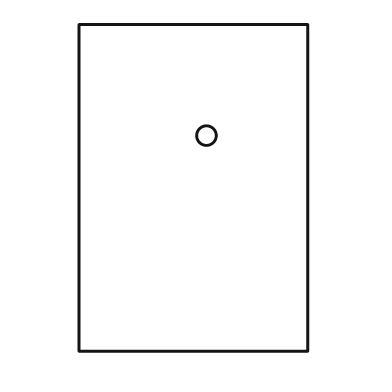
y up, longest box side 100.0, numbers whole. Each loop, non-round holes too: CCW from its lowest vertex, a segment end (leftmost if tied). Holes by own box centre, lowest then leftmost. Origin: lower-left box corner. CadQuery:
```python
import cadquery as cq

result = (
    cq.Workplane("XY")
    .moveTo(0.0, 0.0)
    .lineTo(70.0, 0.0)
    .lineTo(70.0, 100.0)
    .lineTo(0.0, 100.0)
    .close()
    .moveTo(39.0, 66.0)
    .circle(3.0)
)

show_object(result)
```